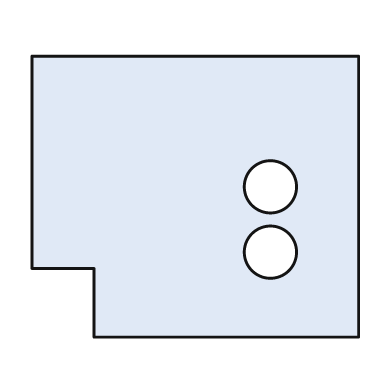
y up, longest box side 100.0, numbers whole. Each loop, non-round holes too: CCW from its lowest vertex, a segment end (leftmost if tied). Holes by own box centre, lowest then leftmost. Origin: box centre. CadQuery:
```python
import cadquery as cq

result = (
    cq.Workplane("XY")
    .moveTo(-31.0, -43.0)
    .lineTo(50.0, -43.0)
    .lineTo(50.0, 43.0)
    .lineTo(-50.0, 43.0)
    .lineTo(-50.0, -22.0)
    .lineTo(-31.0, -22.0)
    .close()
    .moveTo(23.0, -17.0)
    .circle(8.0)
    .moveTo(23.0, 3.0)
    .circle(8.0)
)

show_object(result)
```